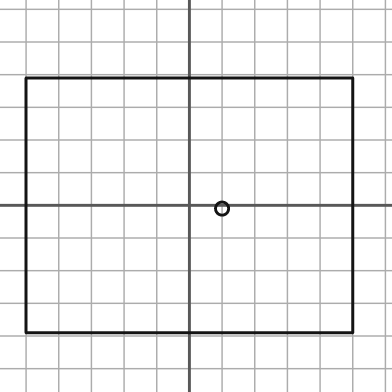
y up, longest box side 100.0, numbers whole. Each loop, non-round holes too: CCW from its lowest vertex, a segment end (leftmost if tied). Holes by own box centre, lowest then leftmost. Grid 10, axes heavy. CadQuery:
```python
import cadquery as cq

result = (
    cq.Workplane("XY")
    .moveTo(-50.0, -39.0)
    .lineTo(50.0, -39.0)
    .lineTo(50.0, 39.0)
    .lineTo(-50.0, 39.0)
    .close()
    .moveTo(10.0, -1.0)
    .circle(2.0)
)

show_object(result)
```